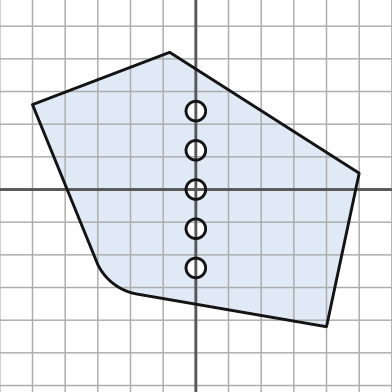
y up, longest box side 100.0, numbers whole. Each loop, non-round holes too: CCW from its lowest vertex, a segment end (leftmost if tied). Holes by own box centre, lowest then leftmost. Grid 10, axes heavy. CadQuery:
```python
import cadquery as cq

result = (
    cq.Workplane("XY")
    .moveTo(40.0, -42.0)
    .lineTo(50.0, 5.0)
    .lineTo(-8.0, 42.0)
    .lineTo(-50.0, 26.0)
    .lineTo(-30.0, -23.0)
    .threePointArc((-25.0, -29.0), (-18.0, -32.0))
    .close()
    .moveTo(0.0, -24.0)
    .circle(3.0)
    .moveTo(0.0, -12.0)
    .circle(3.0)
    .moveTo(0.0, 0.0)
    .circle(3.0)
    .moveTo(0.0, 12.0)
    .circle(3.0)
    .moveTo(0.0, 24.0)
    .circle(3.0)
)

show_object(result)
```